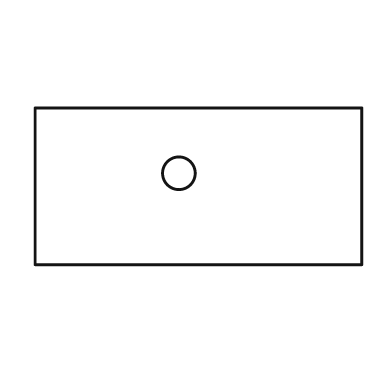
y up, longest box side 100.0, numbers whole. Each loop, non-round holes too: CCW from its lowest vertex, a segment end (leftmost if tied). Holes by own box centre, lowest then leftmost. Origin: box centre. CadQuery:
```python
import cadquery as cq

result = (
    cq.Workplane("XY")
    .moveTo(-50.0, -24.0)
    .lineTo(50.0, -24.0)
    .lineTo(50.0, 24.0)
    .lineTo(-50.0, 24.0)
    .close()
    .moveTo(-6.0, 4.0)
    .circle(5.0)
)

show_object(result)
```